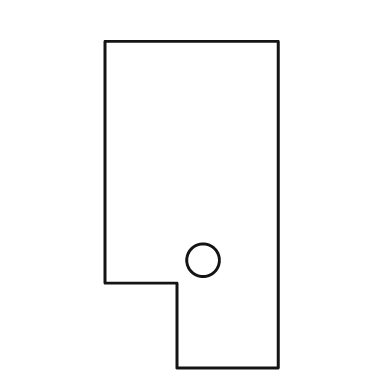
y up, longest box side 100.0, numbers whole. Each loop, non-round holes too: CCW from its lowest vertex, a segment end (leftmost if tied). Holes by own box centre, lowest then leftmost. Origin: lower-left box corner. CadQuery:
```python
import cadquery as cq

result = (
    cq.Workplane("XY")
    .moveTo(22.0, 0.0)
    .lineTo(53.0, 0.0)
    .lineTo(53.0, 100.0)
    .lineTo(0.0, 100.0)
    .lineTo(0.0, 26.0)
    .lineTo(22.0, 26.0)
    .close()
    .moveTo(30.0, 33.0)
    .circle(5.0)
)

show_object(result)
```